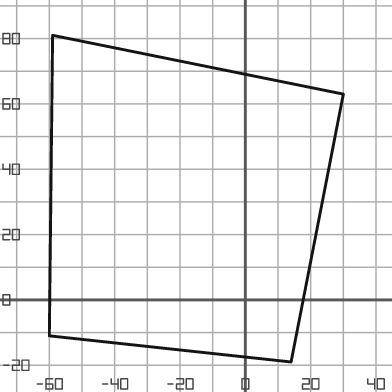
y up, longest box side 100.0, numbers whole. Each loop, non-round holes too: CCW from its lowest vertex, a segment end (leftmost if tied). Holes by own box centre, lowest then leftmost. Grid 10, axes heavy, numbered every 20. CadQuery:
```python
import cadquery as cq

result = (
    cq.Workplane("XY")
    .moveTo(14.0, -19.0)
    .lineTo(30.0, 63.0)
    .lineTo(-59.0, 81.0)
    .lineTo(-60.0, -11.0)
    .close()
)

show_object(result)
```